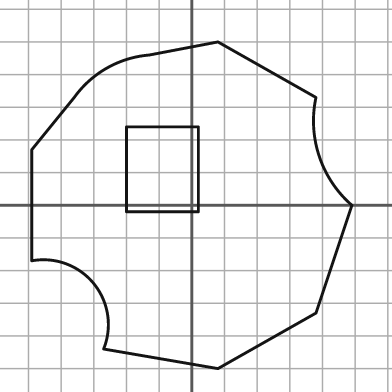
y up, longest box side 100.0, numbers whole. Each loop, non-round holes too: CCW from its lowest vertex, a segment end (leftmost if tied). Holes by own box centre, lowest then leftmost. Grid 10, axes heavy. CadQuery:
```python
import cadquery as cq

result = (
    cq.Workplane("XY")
    .moveTo(8.0, -50.0)
    .lineTo(38.0, -33.0)
    .lineTo(49.0, 0.0)
    .threePointArc((39.0, 15.0), (38.0, 33.0))
    .lineTo(8.0, 50.0)
    .lineTo(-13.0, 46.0)
    .threePointArc((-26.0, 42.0), (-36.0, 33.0))
    .lineTo(-49.0, 17.0)
    .lineTo(-49.0, -17.0)
    .threePointArc((-30.0, -24.0), (-27.0, -44.0))
    .close()
    .moveTo(-20.0, -2.0)
    .lineTo(2.0, -2.0)
    .lineTo(2.0, 24.0)
    .lineTo(-20.0, 24.0)
    .close()
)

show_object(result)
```